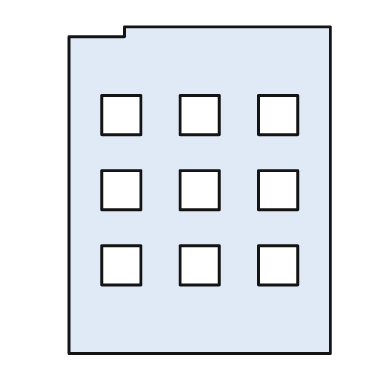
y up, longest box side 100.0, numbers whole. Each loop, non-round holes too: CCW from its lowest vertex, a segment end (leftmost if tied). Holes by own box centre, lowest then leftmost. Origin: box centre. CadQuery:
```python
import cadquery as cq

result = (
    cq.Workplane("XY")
    .moveTo(-40.0, -50.0)
    .lineTo(40.0, -50.0)
    .lineTo(40.0, 50.0)
    .lineTo(-23.0, 50.0)
    .lineTo(-23.0, 47.0)
    .lineTo(-40.0, 47.0)
    .close()
    .moveTo(-30.0, -29.0)
    .lineTo(-18.0, -29.0)
    .lineTo(-18.0, -17.0)
    .lineTo(-30.0, -17.0)
    .close()
    .moveTo(-6.0, -29.0)
    .lineTo(6.0, -29.0)
    .lineTo(6.0, -17.0)
    .lineTo(-6.0, -17.0)
    .close()
    .moveTo(18.0, -29.0)
    .lineTo(30.0, -29.0)
    .lineTo(30.0, -17.0)
    .lineTo(18.0, -17.0)
    .close()
    .moveTo(-30.0, -6.0)
    .lineTo(-18.0, -6.0)
    .lineTo(-18.0, 6.0)
    .lineTo(-30.0, 6.0)
    .close()
    .moveTo(-6.0, -6.0)
    .lineTo(6.0, -6.0)
    .lineTo(6.0, 6.0)
    .lineTo(-6.0, 6.0)
    .close()
    .moveTo(18.0, -6.0)
    .lineTo(30.0, -6.0)
    .lineTo(30.0, 6.0)
    .lineTo(18.0, 6.0)
    .close()
    .moveTo(-30.0, 17.0)
    .lineTo(-18.0, 17.0)
    .lineTo(-18.0, 29.0)
    .lineTo(-30.0, 29.0)
    .close()
    .moveTo(-6.0, 17.0)
    .lineTo(6.0, 17.0)
    .lineTo(6.0, 29.0)
    .lineTo(-6.0, 29.0)
    .close()
    .moveTo(18.0, 17.0)
    .lineTo(30.0, 17.0)
    .lineTo(30.0, 29.0)
    .lineTo(18.0, 29.0)
    .close()
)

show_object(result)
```